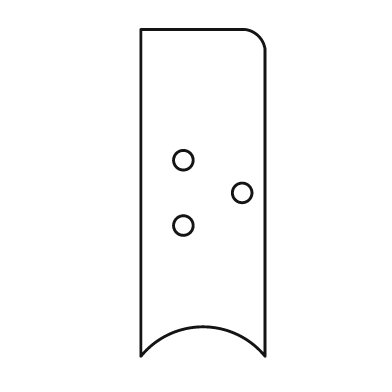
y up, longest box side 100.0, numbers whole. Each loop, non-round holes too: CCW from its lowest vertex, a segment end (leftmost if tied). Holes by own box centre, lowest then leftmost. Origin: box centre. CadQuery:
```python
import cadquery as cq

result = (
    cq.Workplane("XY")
    .moveTo(-19.0, -50.0)
    .threePointArc((0.0, -41.0), (19.0, -50.0))
    .lineTo(19.0, 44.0)
    .threePointArc((17.0, 48.0), (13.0, 50.0))
    .lineTo(-19.0, 50.0)
    .close()
    .moveTo(-6.0, -10.0)
    .circle(3.0)
    .moveTo(12.0, 0.0)
    .circle(3.0)
    .moveTo(-6.0, 10.0)
    .circle(3.0)
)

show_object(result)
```